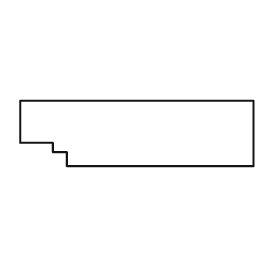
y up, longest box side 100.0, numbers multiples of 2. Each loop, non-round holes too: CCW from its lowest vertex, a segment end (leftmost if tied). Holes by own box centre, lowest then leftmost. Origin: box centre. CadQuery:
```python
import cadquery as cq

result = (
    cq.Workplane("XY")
    .moveTo(-30.0, -14.0)
    .lineTo(50.0, -14.0)
    .lineTo(50.0, 14.0)
    .lineTo(-50.0, 14.0)
    .lineTo(-50.0, -4.0)
    .lineTo(-36.0, -4.0)
    .lineTo(-36.0, -8.0)
    .lineTo(-30.0, -8.0)
    .close()
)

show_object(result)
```